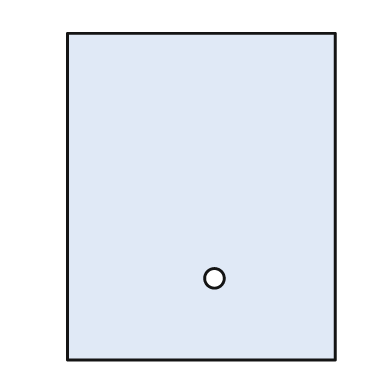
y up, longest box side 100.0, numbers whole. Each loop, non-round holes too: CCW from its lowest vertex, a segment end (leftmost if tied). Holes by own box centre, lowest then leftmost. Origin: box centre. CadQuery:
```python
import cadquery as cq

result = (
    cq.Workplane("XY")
    .moveTo(-41.0, -50.0)
    .lineTo(41.0, -50.0)
    .lineTo(41.0, 50.0)
    .lineTo(-41.0, 50.0)
    .close()
    .moveTo(4.0, -25.0)
    .circle(3.0)
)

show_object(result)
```